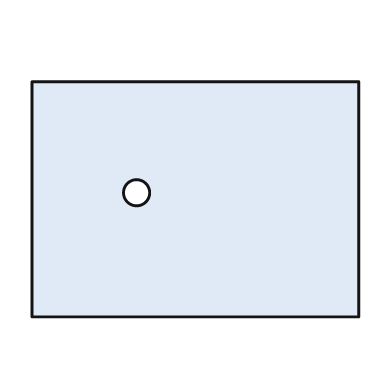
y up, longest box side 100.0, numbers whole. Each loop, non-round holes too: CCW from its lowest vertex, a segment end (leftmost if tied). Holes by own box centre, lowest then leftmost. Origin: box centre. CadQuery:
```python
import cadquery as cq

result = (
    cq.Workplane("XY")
    .moveTo(-50.0, -36.0)
    .lineTo(50.0, -36.0)
    .lineTo(50.0, 36.0)
    .lineTo(-50.0, 36.0)
    .close()
    .moveTo(-18.0, 2.0)
    .circle(4.0)
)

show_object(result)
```